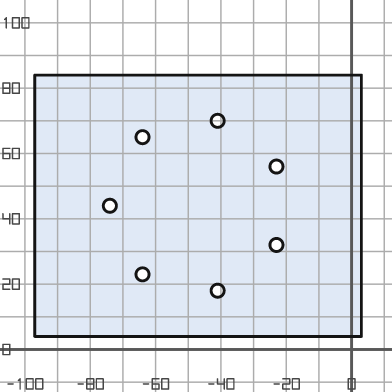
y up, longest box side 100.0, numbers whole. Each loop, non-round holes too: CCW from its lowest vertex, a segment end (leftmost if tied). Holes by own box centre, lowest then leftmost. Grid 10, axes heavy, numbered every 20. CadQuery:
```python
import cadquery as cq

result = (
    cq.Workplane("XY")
    .moveTo(-97.0, 4.0)
    .lineTo(3.0, 4.0)
    .lineTo(3.0, 84.0)
    .lineTo(-97.0, 84.0)
    .close()
    .moveTo(-41.0, 18.0)
    .circle(2.0)
    .moveTo(-64.0, 23.0)
    .circle(2.0)
    .moveTo(-23.0, 32.0)
    .circle(2.0)
    .moveTo(-74.0, 44.0)
    .circle(2.0)
    .moveTo(-23.0, 56.0)
    .circle(2.0)
    .moveTo(-64.0, 65.0)
    .circle(2.0)
    .moveTo(-41.0, 70.0)
    .circle(2.0)
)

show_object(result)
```